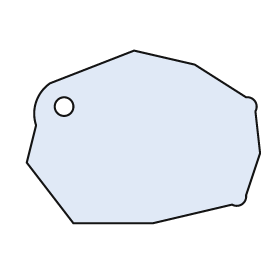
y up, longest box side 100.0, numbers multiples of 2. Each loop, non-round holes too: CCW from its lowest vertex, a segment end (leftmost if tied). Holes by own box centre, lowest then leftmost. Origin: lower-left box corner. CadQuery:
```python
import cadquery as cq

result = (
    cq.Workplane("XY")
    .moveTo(20.0, 0.0)
    .lineTo(54.0, 0.0)
    .lineTo(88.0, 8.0)
    .threePointArc((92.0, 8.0), (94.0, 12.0))
    .lineTo(100.0, 30.0)
    .lineTo(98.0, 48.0)
    .threePointArc((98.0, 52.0), (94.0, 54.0))
    .lineTo(72.0, 68.0)
    .lineTo(46.0, 74.0)
    .lineTo(10.0, 60.0)
    .threePointArc((4.0, 52.0), (4.0, 42.0))
    .lineTo(0.0, 26.0)
    .close()
    .moveTo(16.0, 50.0)
    .circle(4.0)
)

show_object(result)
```